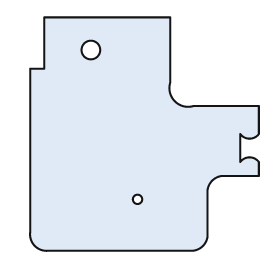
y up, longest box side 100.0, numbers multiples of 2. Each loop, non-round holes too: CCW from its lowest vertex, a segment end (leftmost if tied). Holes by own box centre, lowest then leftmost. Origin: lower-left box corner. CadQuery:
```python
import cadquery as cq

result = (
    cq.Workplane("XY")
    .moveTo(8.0, 0.0)
    .lineTo(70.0, 0.0)
    .threePointArc((74.0, 2.0), (76.0, 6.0))
    .lineTo(76.0, 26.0)
    .threePointArc((78.0, 30.0), (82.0, 32.0))
    .lineTo(98.0, 32.0)
    .lineTo(98.0, 38.0)
    .threePointArc((94.0, 40.0), (90.0, 38.0))
    .lineTo(90.0, 50.0)
    .threePointArc((94.0, 48.0), (98.0, 50.0))
    .lineTo(98.0, 62.0)
    .lineTo(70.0, 62.0)
    .threePointArc((62.0, 64.0), (60.0, 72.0))
    .lineTo(60.0, 100.0)
    .lineTo(6.0, 100.0)
    .lineTo(6.0, 78.0)
    .lineTo(0.0, 78.0)
    .lineTo(0.0, 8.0)
    .threePointArc((2.0, 2.0), (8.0, 0.0))
    .close()
    .moveTo(46.0, 22.0)
    .circle(2.0)
    .moveTo(26.0, 86.0)
    .circle(4.0)
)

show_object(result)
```